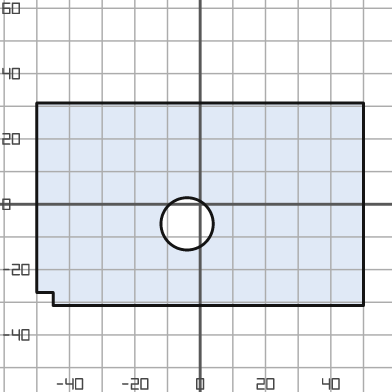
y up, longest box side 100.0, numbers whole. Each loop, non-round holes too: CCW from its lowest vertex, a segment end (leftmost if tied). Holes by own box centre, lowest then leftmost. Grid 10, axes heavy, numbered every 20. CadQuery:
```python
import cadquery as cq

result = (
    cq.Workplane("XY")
    .moveTo(-45.0, -31.0)
    .lineTo(50.0, -31.0)
    .lineTo(50.0, 31.0)
    .lineTo(-50.0, 31.0)
    .lineTo(-50.0, -27.0)
    .lineTo(-45.0, -27.0)
    .close()
    .moveTo(-4.0, -6.0)
    .circle(8.0)
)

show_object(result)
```